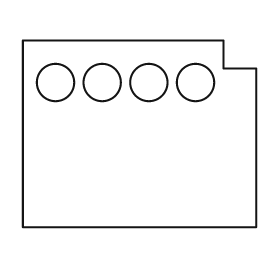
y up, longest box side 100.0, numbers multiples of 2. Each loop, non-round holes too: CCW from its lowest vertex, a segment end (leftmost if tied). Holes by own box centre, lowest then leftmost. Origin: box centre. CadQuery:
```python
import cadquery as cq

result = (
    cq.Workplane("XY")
    .moveTo(-50.0, -40.0)
    .lineTo(50.0, -40.0)
    .lineTo(50.0, 28.0)
    .lineTo(36.0, 28.0)
    .lineTo(36.0, 40.0)
    .lineTo(-50.0, 40.0)
    .close()
    .moveTo(-36.0, 22.0)
    .circle(8.0)
    .moveTo(-16.0, 22.0)
    .circle(8.0)
    .moveTo(4.0, 22.0)
    .circle(8.0)
    .moveTo(24.0, 22.0)
    .circle(8.0)
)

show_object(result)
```